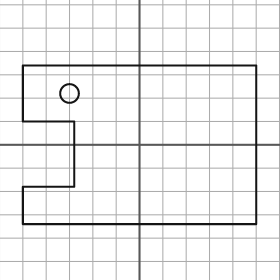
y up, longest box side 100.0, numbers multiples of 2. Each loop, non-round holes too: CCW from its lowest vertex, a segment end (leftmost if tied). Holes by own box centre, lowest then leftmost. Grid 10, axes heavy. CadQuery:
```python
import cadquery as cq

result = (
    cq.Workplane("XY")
    .moveTo(-50.0, -34.0)
    .lineTo(50.0, -34.0)
    .lineTo(50.0, 34.0)
    .lineTo(-50.0, 34.0)
    .lineTo(-50.0, 10.0)
    .lineTo(-28.0, 10.0)
    .lineTo(-28.0, -18.0)
    .lineTo(-50.0, -18.0)
    .close()
    .moveTo(-30.0, 22.0)
    .circle(4.0)
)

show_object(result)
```